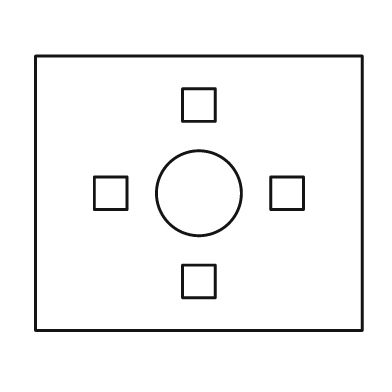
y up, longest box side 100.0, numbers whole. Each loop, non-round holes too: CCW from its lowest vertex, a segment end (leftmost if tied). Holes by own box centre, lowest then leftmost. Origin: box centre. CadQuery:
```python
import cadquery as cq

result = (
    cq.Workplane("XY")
    .moveTo(-50.0, -42.0)
    .lineTo(50.0, -42.0)
    .lineTo(50.0, 42.0)
    .lineTo(-50.0, 42.0)
    .close()
    .moveTo(-5.0, -32.0)
    .lineTo(5.0, -32.0)
    .lineTo(5.0, -22.0)
    .lineTo(-5.0, -22.0)
    .close()
    .moveTo(-32.0, -5.0)
    .lineTo(-22.0, -5.0)
    .lineTo(-22.0, 5.0)
    .lineTo(-32.0, 5.0)
    .close()
    .moveTo(0.0, 0.0)
    .circle(13.0)
    .moveTo(22.0, -5.0)
    .lineTo(32.0, -5.0)
    .lineTo(32.0, 5.0)
    .lineTo(22.0, 5.0)
    .close()
    .moveTo(-5.0, 22.0)
    .lineTo(5.0, 22.0)
    .lineTo(5.0, 32.0)
    .lineTo(-5.0, 32.0)
    .close()
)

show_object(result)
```